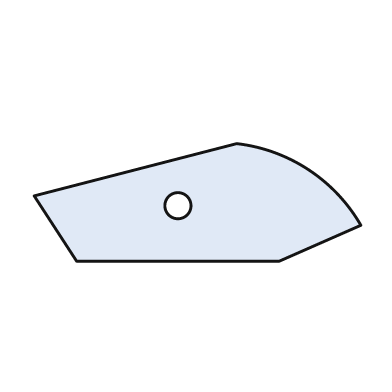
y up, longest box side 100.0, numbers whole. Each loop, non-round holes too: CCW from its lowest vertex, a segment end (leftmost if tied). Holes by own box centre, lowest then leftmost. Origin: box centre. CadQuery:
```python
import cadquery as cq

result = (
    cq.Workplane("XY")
    .moveTo(-37.0, -18.0)
    .lineTo(25.0, -18.0)
    .lineTo(50.0, -7.0)
    .threePointArc((34.0, 10.0), (12.0, 18.0))
    .lineTo(-50.0, 2.0)
    .close()
    .moveTo(-6.0, -1.0)
    .circle(4.0)
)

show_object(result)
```